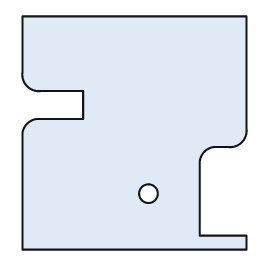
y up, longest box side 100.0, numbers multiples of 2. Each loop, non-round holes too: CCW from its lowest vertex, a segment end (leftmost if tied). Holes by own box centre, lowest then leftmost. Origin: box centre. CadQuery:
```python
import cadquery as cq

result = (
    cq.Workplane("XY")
    .moveTo(-48.0, -50.0)
    .lineTo(48.0, -50.0)
    .lineTo(48.0, -44.0)
    .lineTo(28.0, -44.0)
    .lineTo(28.0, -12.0)
    .threePointArc((30.0, -8.0), (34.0, -6.0))
    .lineTo(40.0, -6.0)
    .threePointArc((46.0, -4.0), (48.0, 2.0))
    .lineTo(48.0, 50.0)
    .lineTo(-48.0, 50.0)
    .lineTo(-48.0, 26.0)
    .threePointArc((-46.0, 20.0), (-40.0, 18.0))
    .lineTo(-22.0, 18.0)
    .lineTo(-22.0, 6.0)
    .lineTo(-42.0, 6.0)
    .threePointArc((-46.0, 4.0), (-48.0, 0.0))
    .close()
    .moveTo(6.0, -26.0)
    .circle(4.0)
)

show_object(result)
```